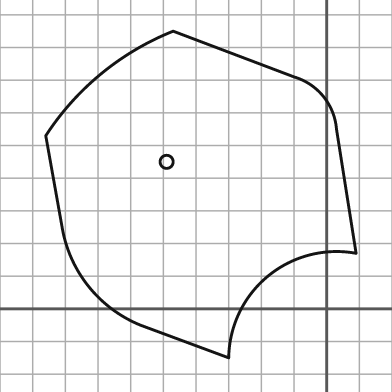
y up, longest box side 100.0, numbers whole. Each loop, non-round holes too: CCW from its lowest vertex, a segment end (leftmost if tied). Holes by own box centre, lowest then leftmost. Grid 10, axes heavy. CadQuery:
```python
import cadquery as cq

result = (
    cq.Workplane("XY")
    .moveTo(-30.0, -15.0)
    .threePointArc((-18.0, 10.0), (9.0, 17.0))
    .lineTo(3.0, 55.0)
    .threePointArc((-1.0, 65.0), (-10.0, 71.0))
    .lineTo(-47.0, 85.0)
    .threePointArc((-69.0, 72.0), (-86.0, 53.0))
    .lineTo(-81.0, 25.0)
    .threePointArc((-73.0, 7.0), (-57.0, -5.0))
    .close()
    .moveTo(-49.0, 45.0)
    .circle(2.0)
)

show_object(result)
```